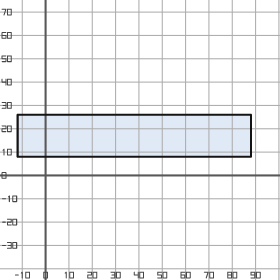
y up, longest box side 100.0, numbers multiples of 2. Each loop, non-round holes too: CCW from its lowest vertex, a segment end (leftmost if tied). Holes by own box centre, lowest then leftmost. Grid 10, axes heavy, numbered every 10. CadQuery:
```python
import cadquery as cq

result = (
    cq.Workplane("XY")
    .moveTo(-12.0, 8.0)
    .lineTo(88.0, 8.0)
    .lineTo(88.0, 26.0)
    .lineTo(-12.0, 26.0)
    .close()
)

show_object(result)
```